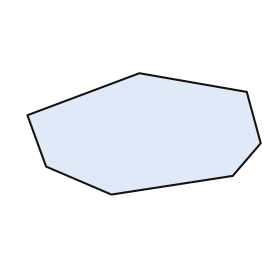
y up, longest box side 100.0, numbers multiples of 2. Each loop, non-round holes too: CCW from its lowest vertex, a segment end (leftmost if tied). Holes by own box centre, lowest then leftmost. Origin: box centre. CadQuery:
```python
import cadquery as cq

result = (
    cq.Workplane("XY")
    .moveTo(-14.0, -26.0)
    .lineTo(38.0, -18.0)
    .lineTo(50.0, -4.0)
    .lineTo(44.0, 18.0)
    .lineTo(-2.0, 26.0)
    .lineTo(-50.0, 8.0)
    .lineTo(-42.0, -14.0)
    .close()
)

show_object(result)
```